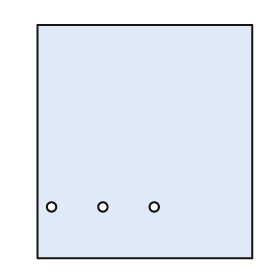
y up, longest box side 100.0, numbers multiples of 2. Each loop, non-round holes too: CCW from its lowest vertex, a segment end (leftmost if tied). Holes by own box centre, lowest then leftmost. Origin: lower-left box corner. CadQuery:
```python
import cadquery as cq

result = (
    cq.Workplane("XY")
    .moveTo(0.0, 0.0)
    .lineTo(92.0, 0.0)
    .lineTo(92.0, 100.0)
    .lineTo(0.0, 100.0)
    .close()
    .moveTo(6.0, 22.0)
    .circle(2.0)
    .moveTo(28.0, 22.0)
    .circle(2.0)
    .moveTo(50.0, 22.0)
    .circle(2.0)
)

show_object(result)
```